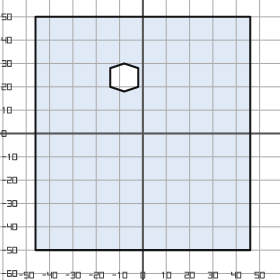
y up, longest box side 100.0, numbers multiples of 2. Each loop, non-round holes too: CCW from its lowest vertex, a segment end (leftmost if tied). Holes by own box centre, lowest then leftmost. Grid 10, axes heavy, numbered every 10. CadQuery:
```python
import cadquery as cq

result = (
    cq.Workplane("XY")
    .moveTo(-46.0, -50.0)
    .lineTo(46.0, -50.0)
    .lineTo(46.0, 50.0)
    .lineTo(-46.0, 50.0)
    .close()
    .moveTo(-8.0, 18.0)
    .lineTo(-2.0, 20.0)
    .lineTo(-2.0, 28.0)
    .lineTo(-8.0, 30.0)
    .lineTo(-14.0, 28.0)
    .lineTo(-14.0, 20.0)
    .close()
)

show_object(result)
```